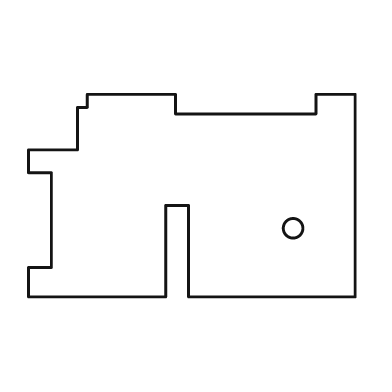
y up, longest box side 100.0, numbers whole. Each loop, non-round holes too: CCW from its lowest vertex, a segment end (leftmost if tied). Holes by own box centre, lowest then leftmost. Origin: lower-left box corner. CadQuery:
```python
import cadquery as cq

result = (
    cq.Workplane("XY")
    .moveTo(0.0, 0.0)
    .lineTo(42.0, 0.0)
    .lineTo(42.0, 28.0)
    .lineTo(49.0, 28.0)
    .lineTo(49.0, 0.0)
    .lineTo(100.0, 0.0)
    .lineTo(100.0, 62.0)
    .lineTo(88.0, 62.0)
    .lineTo(88.0, 56.0)
    .lineTo(45.0, 56.0)
    .lineTo(45.0, 62.0)
    .lineTo(18.0, 62.0)
    .lineTo(18.0, 58.0)
    .lineTo(15.0, 58.0)
    .lineTo(15.0, 45.0)
    .lineTo(0.0, 45.0)
    .lineTo(0.0, 38.0)
    .lineTo(7.0, 38.0)
    .lineTo(7.0, 9.0)
    .lineTo(0.0, 9.0)
    .close()
    .moveTo(81.0, 21.0)
    .circle(3.0)
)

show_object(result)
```